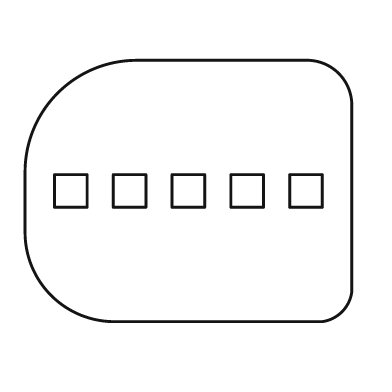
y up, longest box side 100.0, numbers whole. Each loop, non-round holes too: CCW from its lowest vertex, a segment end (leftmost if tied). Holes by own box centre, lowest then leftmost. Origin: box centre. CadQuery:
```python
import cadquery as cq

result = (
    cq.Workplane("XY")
    .moveTo(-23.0, -40.0)
    .lineTo(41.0, -40.0)
    .threePointArc((47.0, -37.0), (50.0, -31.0))
    .lineTo(50.0, 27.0)
    .threePointArc((46.0, 36.0), (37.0, 40.0))
    .lineTo(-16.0, 40.0)
    .threePointArc((-40.0, 30.0), (-50.0, 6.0))
    .lineTo(-50.0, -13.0)
    .threePointArc((-42.0, -32.0), (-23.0, -40.0))
    .close()
    .moveTo(-41.0, -5.0)
    .lineTo(-31.0, -5.0)
    .lineTo(-31.0, 5.0)
    .lineTo(-41.0, 5.0)
    .close()
    .moveTo(-23.0, -5.0)
    .lineTo(-13.0, -5.0)
    .lineTo(-13.0, 5.0)
    .lineTo(-23.0, 5.0)
    .close()
    .moveTo(-5.0, -5.0)
    .lineTo(5.0, -5.0)
    .lineTo(5.0, 5.0)
    .lineTo(-5.0, 5.0)
    .close()
    .moveTo(13.0, -5.0)
    .lineTo(23.0, -5.0)
    .lineTo(23.0, 5.0)
    .lineTo(13.0, 5.0)
    .close()
    .moveTo(31.0, -5.0)
    .lineTo(41.0, -5.0)
    .lineTo(41.0, 5.0)
    .lineTo(31.0, 5.0)
    .close()
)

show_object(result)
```